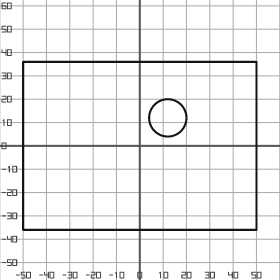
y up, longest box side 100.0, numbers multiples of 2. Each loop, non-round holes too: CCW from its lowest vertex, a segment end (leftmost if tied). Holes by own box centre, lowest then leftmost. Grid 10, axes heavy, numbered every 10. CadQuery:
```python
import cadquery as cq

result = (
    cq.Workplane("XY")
    .moveTo(-50.0, -36.0)
    .lineTo(50.0, -36.0)
    .lineTo(50.0, 36.0)
    .lineTo(-50.0, 36.0)
    .close()
    .moveTo(12.0, 12.0)
    .circle(8.0)
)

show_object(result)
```